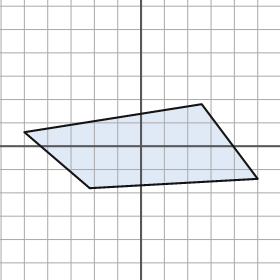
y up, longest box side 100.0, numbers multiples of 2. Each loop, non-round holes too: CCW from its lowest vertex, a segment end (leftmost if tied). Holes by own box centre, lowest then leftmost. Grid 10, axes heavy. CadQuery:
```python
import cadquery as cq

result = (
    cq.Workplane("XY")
    .moveTo(-22.0, -18.0)
    .lineTo(50.0, -14.0)
    .lineTo(26.0, 18.0)
    .lineTo(-50.0, 6.0)
    .close()
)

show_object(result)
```